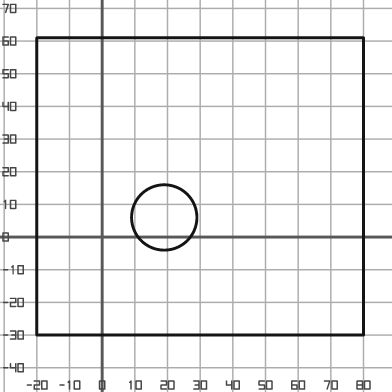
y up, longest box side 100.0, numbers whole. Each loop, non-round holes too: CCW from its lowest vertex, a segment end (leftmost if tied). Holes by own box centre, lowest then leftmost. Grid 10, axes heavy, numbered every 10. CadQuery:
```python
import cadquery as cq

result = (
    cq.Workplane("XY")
    .moveTo(-20.0, -30.0)
    .lineTo(80.0, -30.0)
    .lineTo(80.0, 61.0)
    .lineTo(-20.0, 61.0)
    .close()
    .moveTo(19.0, 6.0)
    .circle(10.0)
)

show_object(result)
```